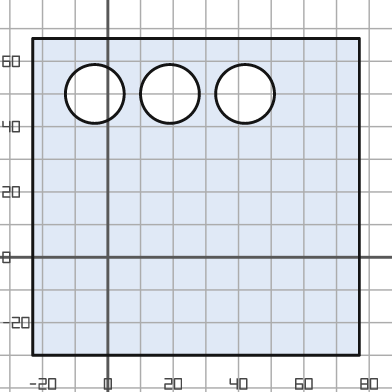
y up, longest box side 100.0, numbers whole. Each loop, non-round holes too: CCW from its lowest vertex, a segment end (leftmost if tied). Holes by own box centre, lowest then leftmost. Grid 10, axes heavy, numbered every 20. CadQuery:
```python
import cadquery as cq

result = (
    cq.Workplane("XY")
    .moveTo(-23.0, -30.0)
    .lineTo(77.0, -30.0)
    .lineTo(77.0, 67.0)
    .lineTo(-23.0, 67.0)
    .close()
    .moveTo(-4.0, 50.0)
    .circle(9.0)
    .moveTo(19.0, 50.0)
    .circle(9.0)
    .moveTo(42.0, 50.0)
    .circle(9.0)
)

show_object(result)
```